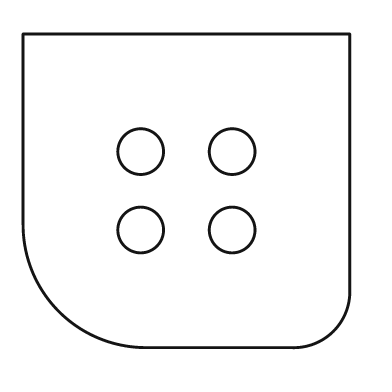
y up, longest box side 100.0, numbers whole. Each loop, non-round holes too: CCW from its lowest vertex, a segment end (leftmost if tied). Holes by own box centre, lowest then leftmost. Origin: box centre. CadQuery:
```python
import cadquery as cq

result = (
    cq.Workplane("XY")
    .moveTo(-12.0, -48.0)
    .lineTo(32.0, -48.0)
    .threePointArc((45.0, -43.0), (50.0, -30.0))
    .lineTo(50.0, 48.0)
    .lineTo(-50.0, 48.0)
    .lineTo(-50.0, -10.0)
    .threePointArc((-39.0, -37.0), (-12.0, -48.0))
    .close()
    .moveTo(-14.0, -12.0)
    .circle(7.0)
    .moveTo(14.0, -12.0)
    .circle(7.0)
    .moveTo(-14.0, 12.0)
    .circle(7.0)
    .moveTo(14.0, 12.0)
    .circle(7.0)
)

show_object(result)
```